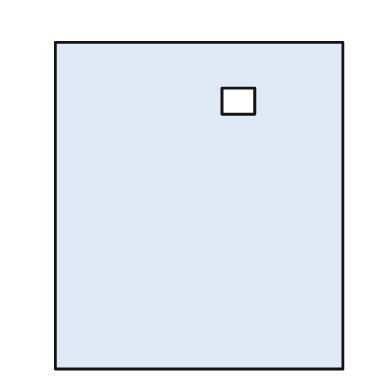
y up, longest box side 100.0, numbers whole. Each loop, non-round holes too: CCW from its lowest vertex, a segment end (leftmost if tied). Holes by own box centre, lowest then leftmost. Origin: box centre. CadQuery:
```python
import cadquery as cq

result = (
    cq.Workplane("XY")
    .moveTo(-44.0, -50.0)
    .lineTo(44.0, -50.0)
    .lineTo(44.0, 50.0)
    .lineTo(-44.0, 50.0)
    .close()
    .moveTo(7.0, 28.0)
    .lineTo(17.0, 28.0)
    .lineTo(17.0, 36.0)
    .lineTo(7.0, 36.0)
    .close()
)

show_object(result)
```